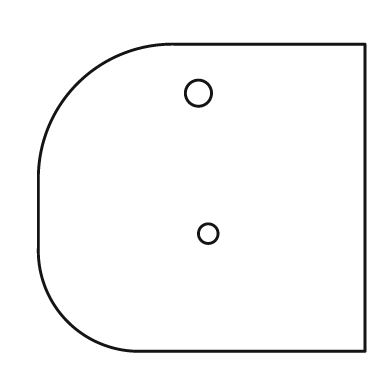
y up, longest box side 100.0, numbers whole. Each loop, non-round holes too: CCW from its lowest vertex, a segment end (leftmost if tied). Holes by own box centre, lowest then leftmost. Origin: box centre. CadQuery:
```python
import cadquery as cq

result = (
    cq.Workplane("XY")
    .moveTo(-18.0, -47.0)
    .lineTo(50.0, -47.0)
    .lineTo(50.0, 47.0)
    .lineTo(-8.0, 47.0)
    .threePointArc((-38.0, 35.0), (-50.0, 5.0))
    .lineTo(-50.0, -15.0)
    .threePointArc((-41.0, -38.0), (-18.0, -47.0))
    .close()
    .moveTo(2.0, -11.0)
    .circle(3.0)
    .moveTo(-1.0, 32.0)
    .circle(4.0)
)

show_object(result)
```